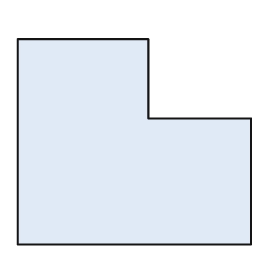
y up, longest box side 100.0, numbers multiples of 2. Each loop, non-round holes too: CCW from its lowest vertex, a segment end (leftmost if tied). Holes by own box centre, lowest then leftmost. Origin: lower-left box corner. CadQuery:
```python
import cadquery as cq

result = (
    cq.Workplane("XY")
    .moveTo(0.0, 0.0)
    .lineTo(100.0, 0.0)
    .lineTo(100.0, 54.0)
    .lineTo(56.0, 54.0)
    .lineTo(56.0, 88.0)
    .lineTo(0.0, 88.0)
    .close()
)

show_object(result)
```